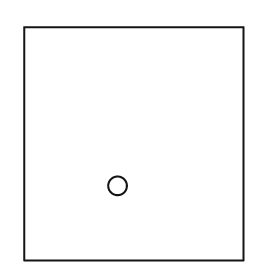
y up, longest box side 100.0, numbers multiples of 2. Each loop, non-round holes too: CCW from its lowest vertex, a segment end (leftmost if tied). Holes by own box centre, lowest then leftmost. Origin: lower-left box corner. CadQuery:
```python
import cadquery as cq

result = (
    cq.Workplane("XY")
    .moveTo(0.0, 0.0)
    .lineTo(94.0, 0.0)
    .lineTo(94.0, 100.0)
    .lineTo(0.0, 100.0)
    .close()
    .moveTo(40.0, 32.0)
    .circle(4.0)
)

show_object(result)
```